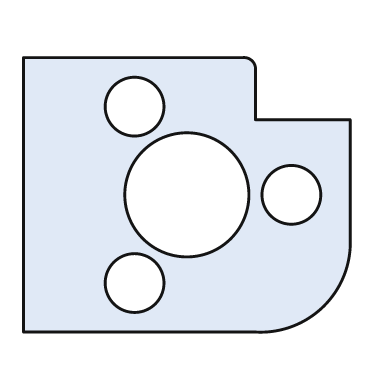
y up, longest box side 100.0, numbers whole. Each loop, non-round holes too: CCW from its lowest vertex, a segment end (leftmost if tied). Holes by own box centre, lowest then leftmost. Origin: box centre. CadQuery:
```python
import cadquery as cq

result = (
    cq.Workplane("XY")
    .moveTo(-50.0, -42.0)
    .lineTo(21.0, -42.0)
    .threePointArc((42.0, -34.0), (50.0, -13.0))
    .lineTo(50.0, 23.0)
    .lineTo(21.0, 23.0)
    .lineTo(21.0, 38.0)
    .threePointArc((20.0, 41.0), (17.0, 42.0))
    .lineTo(-50.0, 42.0)
    .close()
    .moveTo(-16.0, -27.0)
    .circle(9.0)
    .moveTo(0.0, 0.0)
    .circle(19.0)
    .moveTo(32.0, 0.0)
    .circle(9.0)
    .moveTo(-16.0, 27.0)
    .circle(9.0)
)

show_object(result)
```